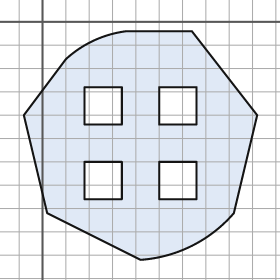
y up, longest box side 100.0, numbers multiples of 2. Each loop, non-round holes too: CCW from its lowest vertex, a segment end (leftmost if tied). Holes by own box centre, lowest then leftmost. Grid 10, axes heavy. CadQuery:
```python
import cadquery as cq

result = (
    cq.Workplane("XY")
    .moveTo(42.0, -102.0)
    .threePointArc((64.0, -96.0), (82.0, -82.0))
    .lineTo(92.0, -40.0)
    .lineTo(64.0, -4.0)
    .lineTo(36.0, -4.0)
    .threePointArc((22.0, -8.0), (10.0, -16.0))
    .lineTo(-8.0, -40.0)
    .lineTo(2.0, -82.0)
    .close()
    .moveTo(18.0, -76.0)
    .lineTo(34.0, -76.0)
    .lineTo(34.0, -60.0)
    .lineTo(18.0, -60.0)
    .close()
    .moveTo(50.0, -76.0)
    .lineTo(66.0, -76.0)
    .lineTo(66.0, -60.0)
    .lineTo(50.0, -60.0)
    .close()
    .moveTo(18.0, -44.0)
    .lineTo(34.0, -44.0)
    .lineTo(34.0, -28.0)
    .lineTo(18.0, -28.0)
    .close()
    .moveTo(50.0, -44.0)
    .lineTo(66.0, -44.0)
    .lineTo(66.0, -28.0)
    .lineTo(50.0, -28.0)
    .close()
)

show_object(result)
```